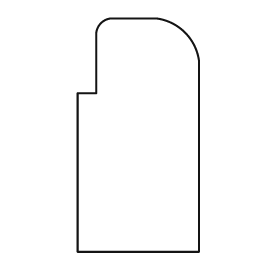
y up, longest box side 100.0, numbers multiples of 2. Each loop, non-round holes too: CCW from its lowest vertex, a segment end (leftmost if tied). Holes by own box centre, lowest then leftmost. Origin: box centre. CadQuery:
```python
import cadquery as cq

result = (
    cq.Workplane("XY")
    .moveTo(-26.0, -50.0)
    .lineTo(26.0, -50.0)
    .lineTo(26.0, 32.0)
    .threePointArc((20.0, 44.0), (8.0, 50.0))
    .lineTo(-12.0, 50.0)
    .threePointArc((-16.0, 48.0), (-18.0, 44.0))
    .lineTo(-18.0, 18.0)
    .lineTo(-26.0, 18.0)
    .close()
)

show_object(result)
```